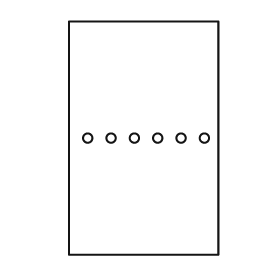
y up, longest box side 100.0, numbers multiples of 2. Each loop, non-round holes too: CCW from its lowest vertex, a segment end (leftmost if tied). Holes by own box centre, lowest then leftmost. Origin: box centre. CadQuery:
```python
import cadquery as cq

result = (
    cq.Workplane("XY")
    .moveTo(-32.0, -50.0)
    .lineTo(32.0, -50.0)
    .lineTo(32.0, 50.0)
    .lineTo(-32.0, 50.0)
    .close()
    .moveTo(-24.0, 0.0)
    .circle(2.0)
    .moveTo(-14.0, 0.0)
    .circle(2.0)
    .moveTo(-4.0, 0.0)
    .circle(2.0)
    .moveTo(6.0, 0.0)
    .circle(2.0)
    .moveTo(16.0, 0.0)
    .circle(2.0)
    .moveTo(26.0, 0.0)
    .circle(2.0)
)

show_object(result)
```